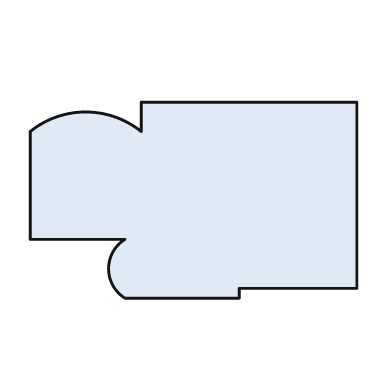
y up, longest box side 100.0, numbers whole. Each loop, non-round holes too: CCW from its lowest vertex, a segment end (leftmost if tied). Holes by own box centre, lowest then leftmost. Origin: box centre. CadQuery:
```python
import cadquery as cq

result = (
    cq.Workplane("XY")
    .moveTo(-21.0, -30.0)
    .lineTo(14.0, -30.0)
    .lineTo(14.0, -27.0)
    .lineTo(50.0, -27.0)
    .lineTo(50.0, 30.0)
    .lineTo(-16.0, 30.0)
    .lineTo(-16.0, 21.0)
    .threePointArc((-33.0, 27.0), (-50.0, 21.0))
    .lineTo(-50.0, -12.0)
    .lineTo(-21.0, -12.0)
    .threePointArc((-26.0, -21.0), (-21.0, -30.0))
    .close()
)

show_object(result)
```